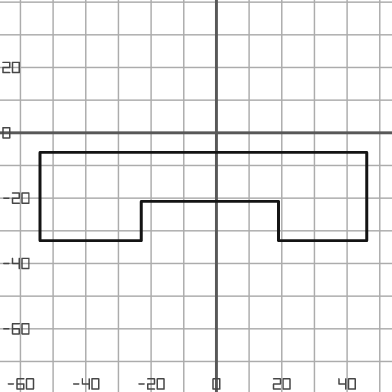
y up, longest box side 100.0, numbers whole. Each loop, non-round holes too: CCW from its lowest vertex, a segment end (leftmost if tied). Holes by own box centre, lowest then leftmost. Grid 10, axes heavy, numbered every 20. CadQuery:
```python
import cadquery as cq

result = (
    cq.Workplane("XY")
    .moveTo(-54.0, -33.0)
    .lineTo(-23.0, -33.0)
    .lineTo(-23.0, -21.0)
    .lineTo(19.0, -21.0)
    .lineTo(19.0, -33.0)
    .lineTo(46.0, -33.0)
    .lineTo(46.0, -6.0)
    .lineTo(-54.0, -6.0)
    .close()
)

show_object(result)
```